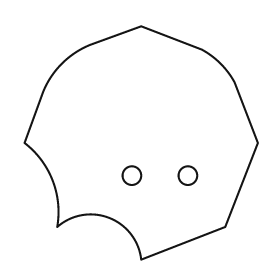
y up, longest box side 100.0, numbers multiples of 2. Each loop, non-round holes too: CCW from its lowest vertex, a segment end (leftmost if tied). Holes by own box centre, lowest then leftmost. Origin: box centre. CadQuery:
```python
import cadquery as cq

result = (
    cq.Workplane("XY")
    .moveTo(0.0, -50.0)
    .lineTo(36.0, -36.0)
    .lineTo(50.0, 0.0)
    .lineTo(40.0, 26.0)
    .threePointArc((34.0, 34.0), (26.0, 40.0))
    .lineTo(0.0, 50.0)
    .lineTo(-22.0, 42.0)
    .threePointArc((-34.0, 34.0), (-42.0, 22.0))
    .lineTo(-50.0, 0.0)
    .threePointArc((-38.0, -16.0), (-36.0, -36.0))
    .threePointArc((-14.0, -32.0), (0.0, -50.0))
    .close()
    .moveTo(-4.0, -14.0)
    .circle(4.0)
    .moveTo(20.0, -14.0)
    .circle(4.0)
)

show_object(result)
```